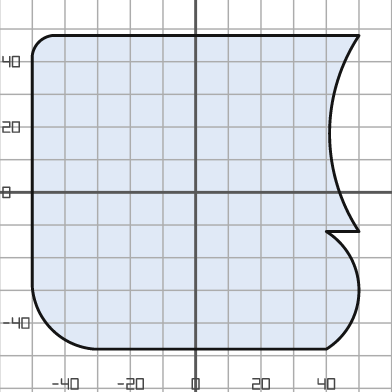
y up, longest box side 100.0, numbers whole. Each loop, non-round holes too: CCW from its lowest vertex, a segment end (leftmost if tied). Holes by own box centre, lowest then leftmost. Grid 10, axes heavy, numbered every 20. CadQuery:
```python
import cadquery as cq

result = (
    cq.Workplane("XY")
    .moveTo(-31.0, -48.0)
    .lineTo(40.0, -48.0)
    .threePointArc((50.0, -30.0), (40.0, -12.0))
    .lineTo(50.0, -12.0)
    .threePointArc((41.0, 18.0), (50.0, 48.0))
    .lineTo(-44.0, 48.0)
    .threePointArc((-48.0, 46.0), (-50.0, 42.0))
    .lineTo(-50.0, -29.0)
    .threePointArc((-44.0, -42.0), (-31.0, -48.0))
    .close()
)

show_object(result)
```